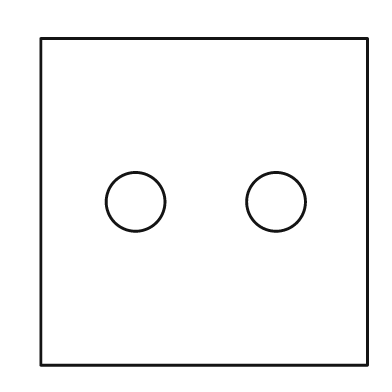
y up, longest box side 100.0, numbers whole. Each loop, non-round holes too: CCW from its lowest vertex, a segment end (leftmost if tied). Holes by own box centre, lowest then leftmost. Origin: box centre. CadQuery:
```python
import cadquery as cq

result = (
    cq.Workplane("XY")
    .moveTo(-50.0, -50.0)
    .lineTo(50.0, -50.0)
    .lineTo(50.0, 50.0)
    .lineTo(-50.0, 50.0)
    .close()
    .moveTo(-21.0, 0.0)
    .circle(9.0)
    .moveTo(22.0, 0.0)
    .circle(9.0)
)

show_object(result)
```